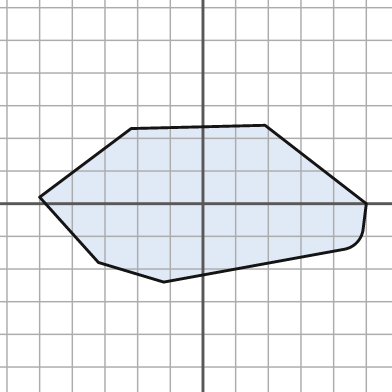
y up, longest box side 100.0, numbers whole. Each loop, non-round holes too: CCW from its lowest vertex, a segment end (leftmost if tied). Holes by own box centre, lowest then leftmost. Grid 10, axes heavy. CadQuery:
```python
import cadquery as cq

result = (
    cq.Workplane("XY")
    .moveTo(-12.0, -24.0)
    .lineTo(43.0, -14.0)
    .threePointArc((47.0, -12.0), (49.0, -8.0))
    .lineTo(50.0, 0.0)
    .lineTo(19.0, 24.0)
    .lineTo(-22.0, 23.0)
    .lineTo(-50.0, 2.0)
    .lineTo(-32.0, -18.0)
    .close()
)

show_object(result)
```